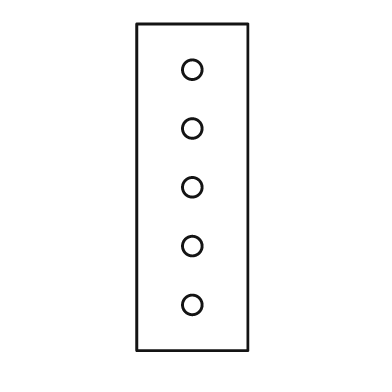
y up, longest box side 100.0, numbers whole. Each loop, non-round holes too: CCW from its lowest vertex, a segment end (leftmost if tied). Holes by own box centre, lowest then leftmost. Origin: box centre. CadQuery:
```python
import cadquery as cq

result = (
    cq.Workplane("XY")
    .moveTo(-17.0, -50.0)
    .lineTo(17.0, -50.0)
    .lineTo(17.0, 50.0)
    .lineTo(-17.0, 50.0)
    .close()
    .moveTo(0.0, -36.0)
    .circle(3.0)
    .moveTo(0.0, -18.0)
    .circle(3.0)
    .moveTo(0.0, 0.0)
    .circle(3.0)
    .moveTo(0.0, 18.0)
    .circle(3.0)
    .moveTo(0.0, 36.0)
    .circle(3.0)
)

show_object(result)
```